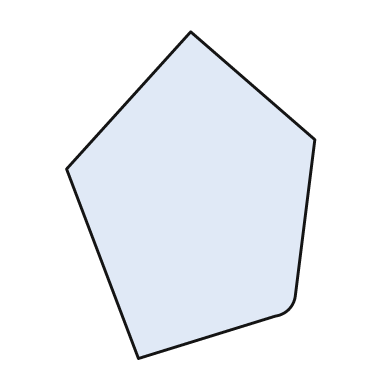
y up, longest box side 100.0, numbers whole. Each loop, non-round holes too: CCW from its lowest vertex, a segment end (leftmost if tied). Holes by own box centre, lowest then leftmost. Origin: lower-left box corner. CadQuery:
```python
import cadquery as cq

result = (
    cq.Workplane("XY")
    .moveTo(22.0, 0.0)
    .lineTo(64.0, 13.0)
    .threePointArc((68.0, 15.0), (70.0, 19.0))
    .lineTo(76.0, 67.0)
    .lineTo(38.0, 100.0)
    .lineTo(0.0, 58.0)
    .close()
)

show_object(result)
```